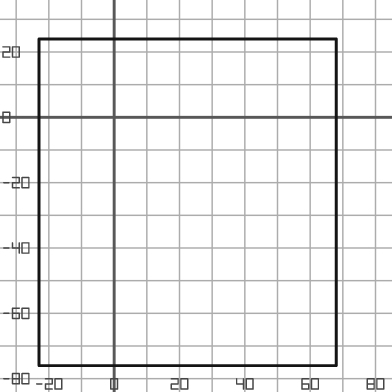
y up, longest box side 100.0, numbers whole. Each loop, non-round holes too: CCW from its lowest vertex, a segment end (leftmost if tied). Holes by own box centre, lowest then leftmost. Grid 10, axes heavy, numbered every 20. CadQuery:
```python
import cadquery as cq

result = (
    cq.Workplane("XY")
    .moveTo(-23.0, -76.0)
    .lineTo(68.0, -76.0)
    .lineTo(68.0, 24.0)
    .lineTo(-23.0, 24.0)
    .close()
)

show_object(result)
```